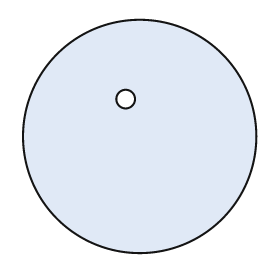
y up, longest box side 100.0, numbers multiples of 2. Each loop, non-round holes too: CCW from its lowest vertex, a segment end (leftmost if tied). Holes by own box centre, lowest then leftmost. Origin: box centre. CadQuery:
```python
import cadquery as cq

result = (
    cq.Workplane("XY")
    .moveTo(0.0, 0.0)
    .circle(50.0)
    .moveTo(-6.0, 16.0)
    .circle(4.0)
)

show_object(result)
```